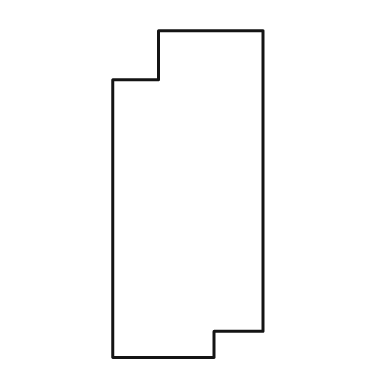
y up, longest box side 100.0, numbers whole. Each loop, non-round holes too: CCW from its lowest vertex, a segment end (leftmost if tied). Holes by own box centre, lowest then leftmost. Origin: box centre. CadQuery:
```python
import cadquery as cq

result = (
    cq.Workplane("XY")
    .moveTo(-23.0, -50.0)
    .lineTo(8.0, -50.0)
    .lineTo(8.0, -42.0)
    .lineTo(23.0, -42.0)
    .lineTo(23.0, 50.0)
    .lineTo(-9.0, 50.0)
    .lineTo(-9.0, 35.0)
    .lineTo(-23.0, 35.0)
    .close()
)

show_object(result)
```